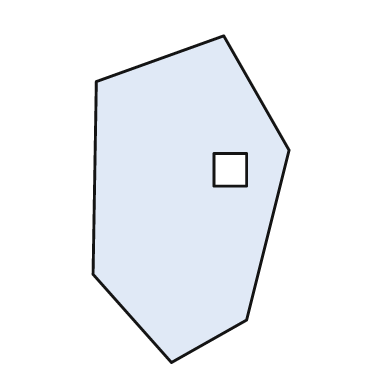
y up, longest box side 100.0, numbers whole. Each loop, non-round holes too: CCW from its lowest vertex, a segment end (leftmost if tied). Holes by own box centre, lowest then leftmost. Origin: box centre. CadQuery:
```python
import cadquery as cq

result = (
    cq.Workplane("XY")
    .moveTo(-6.0, -50.0)
    .lineTo(17.0, -37.0)
    .lineTo(30.0, 15.0)
    .lineTo(10.0, 50.0)
    .lineTo(-29.0, 36.0)
    .lineTo(-30.0, -23.0)
    .close()
    .moveTo(7.0, 4.0)
    .lineTo(17.0, 4.0)
    .lineTo(17.0, 14.0)
    .lineTo(7.0, 14.0)
    .close()
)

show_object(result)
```